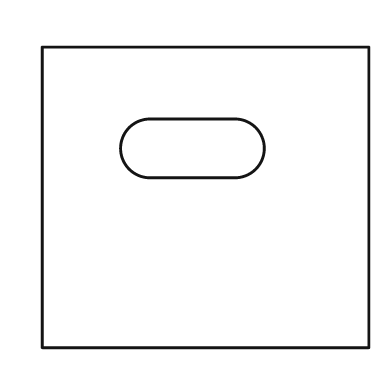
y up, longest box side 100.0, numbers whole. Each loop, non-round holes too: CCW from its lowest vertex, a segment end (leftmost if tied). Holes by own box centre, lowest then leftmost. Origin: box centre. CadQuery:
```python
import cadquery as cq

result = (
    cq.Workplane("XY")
    .moveTo(-50.0, -46.0)
    .lineTo(50.0, -46.0)
    .lineTo(50.0, 46.0)
    .lineTo(-50.0, 46.0)
    .close()
    .moveTo(-17.0, 6.0)
    .lineTo(9.0, 6.0)
    .threePointArc((18.0, 15.0), (9.0, 24.0))
    .lineTo(-17.0, 24.0)
    .threePointArc((-26.0, 15.0), (-17.0, 6.0))
    .close()
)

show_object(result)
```